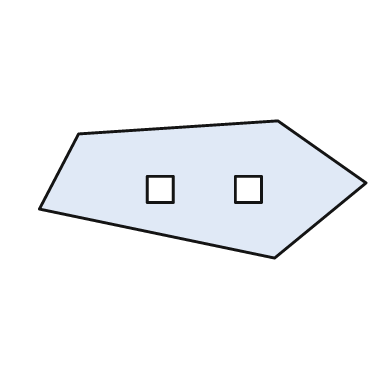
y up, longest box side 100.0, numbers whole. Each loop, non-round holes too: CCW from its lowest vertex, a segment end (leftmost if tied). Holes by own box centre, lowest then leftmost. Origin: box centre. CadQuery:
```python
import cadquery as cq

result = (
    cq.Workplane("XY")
    .moveTo(22.0, -21.0)
    .lineTo(50.0, 2.0)
    .lineTo(23.0, 21.0)
    .lineTo(-38.0, 17.0)
    .lineTo(-50.0, -6.0)
    .close()
    .moveTo(-17.0, -4.0)
    .lineTo(-9.0, -4.0)
    .lineTo(-9.0, 4.0)
    .lineTo(-17.0, 4.0)
    .close()
    .moveTo(10.0, -4.0)
    .lineTo(18.0, -4.0)
    .lineTo(18.0, 4.0)
    .lineTo(10.0, 4.0)
    .close()
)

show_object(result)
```